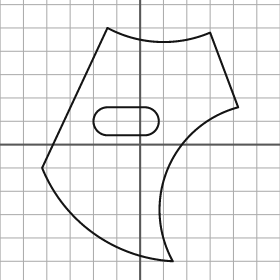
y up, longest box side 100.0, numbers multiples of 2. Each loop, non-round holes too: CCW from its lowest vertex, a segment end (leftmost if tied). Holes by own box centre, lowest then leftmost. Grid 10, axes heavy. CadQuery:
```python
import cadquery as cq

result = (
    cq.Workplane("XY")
    .moveTo(14.0, -50.0)
    .threePointArc((12.0, -10.0), (42.0, 16.0))
    .lineTo(30.0, 48.0)
    .threePointArc((8.0, 44.0), (-14.0, 50.0))
    .lineTo(-42.0, -10.0)
    .threePointArc((-20.0, -38.0), (14.0, -50.0))
    .close()
    .moveTo(-14.0, 4.0)
    .lineTo(2.0, 4.0)
    .threePointArc((8.0, 10.0), (2.0, 16.0))
    .lineTo(-14.0, 16.0)
    .threePointArc((-20.0, 10.0), (-14.0, 4.0))
    .close()
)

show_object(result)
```